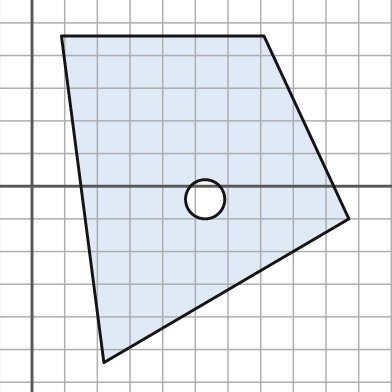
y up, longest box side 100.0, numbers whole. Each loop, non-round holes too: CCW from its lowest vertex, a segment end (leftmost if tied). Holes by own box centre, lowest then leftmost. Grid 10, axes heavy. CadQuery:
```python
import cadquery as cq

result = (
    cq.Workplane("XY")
    .moveTo(22.0, -54.0)
    .lineTo(97.0, -10.0)
    .lineTo(71.0, 46.0)
    .lineTo(9.0, 46.0)
    .close()
    .moveTo(53.0, -4.0)
    .circle(6.0)
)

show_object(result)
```